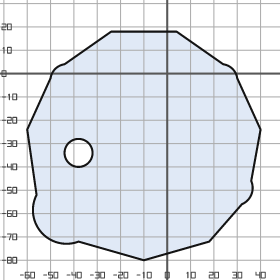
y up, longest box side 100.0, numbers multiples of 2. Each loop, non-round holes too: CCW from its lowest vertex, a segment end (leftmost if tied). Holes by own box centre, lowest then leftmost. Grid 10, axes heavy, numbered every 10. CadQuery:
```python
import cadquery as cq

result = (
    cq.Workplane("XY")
    .moveTo(-10.0, -80.0)
    .lineTo(18.0, -72.0)
    .lineTo(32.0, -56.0)
    .threePointArc((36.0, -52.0), (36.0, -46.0))
    .lineTo(40.0, -24.0)
    .lineTo(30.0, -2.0)
    .threePointArc((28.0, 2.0), (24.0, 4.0))
    .lineTo(4.0, 18.0)
    .lineTo(-24.0, 18.0)
    .lineTo(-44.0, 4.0)
    .threePointArc((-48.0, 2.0), (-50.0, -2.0))
    .lineTo(-60.0, -24.0)
    .lineTo(-56.0, -52.0)
    .threePointArc((-54.0, -68.0), (-38.0, -72.0))
    .close()
    .moveTo(-38.0, -34.0)
    .circle(6.0)
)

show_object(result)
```